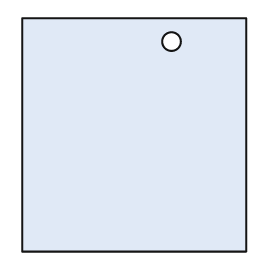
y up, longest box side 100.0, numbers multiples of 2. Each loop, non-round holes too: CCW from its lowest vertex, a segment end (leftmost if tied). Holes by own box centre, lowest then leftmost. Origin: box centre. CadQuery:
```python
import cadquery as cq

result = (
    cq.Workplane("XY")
    .moveTo(-48.0, -50.0)
    .lineTo(48.0, -50.0)
    .lineTo(48.0, 50.0)
    .lineTo(-48.0, 50.0)
    .close()
    .moveTo(16.0, 40.0)
    .circle(4.0)
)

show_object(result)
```